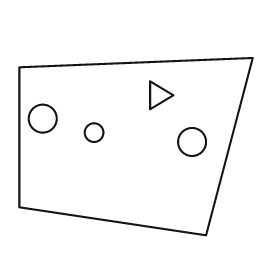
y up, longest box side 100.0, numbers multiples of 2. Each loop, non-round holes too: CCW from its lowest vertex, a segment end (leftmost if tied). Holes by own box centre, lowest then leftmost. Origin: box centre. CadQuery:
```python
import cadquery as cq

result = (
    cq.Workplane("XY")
    .moveTo(30.0, -38.0)
    .lineTo(50.0, 38.0)
    .lineTo(-50.0, 34.0)
    .lineTo(-50.0, -26.0)
    .close()
    .moveTo(24.0, 2.0)
    .circle(6.0)
    .moveTo(-18.0, 6.0)
    .circle(4.0)
    .moveTo(-40.0, 12.0)
    .circle(6.0)
    .moveTo(6.0, 16.0)
    .lineTo(16.0, 22.0)
    .lineTo(6.0, 28.0)
    .close()
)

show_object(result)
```